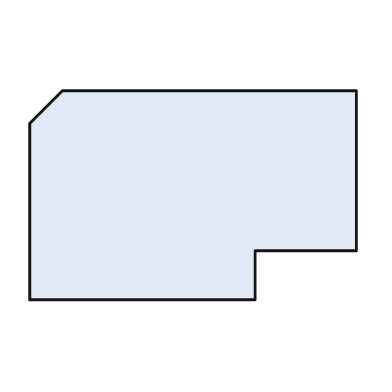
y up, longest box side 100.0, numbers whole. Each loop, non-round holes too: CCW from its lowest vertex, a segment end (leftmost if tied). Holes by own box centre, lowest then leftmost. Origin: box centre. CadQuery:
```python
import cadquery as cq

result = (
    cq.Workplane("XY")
    .moveTo(-50.0, -32.0)
    .lineTo(19.0, -32.0)
    .lineTo(19.0, -17.0)
    .lineTo(50.0, -17.0)
    .lineTo(50.0, 32.0)
    .lineTo(-40.0, 32.0)
    .lineTo(-50.0, 22.0)
    .close()
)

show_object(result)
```